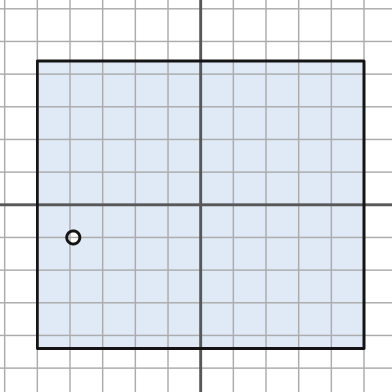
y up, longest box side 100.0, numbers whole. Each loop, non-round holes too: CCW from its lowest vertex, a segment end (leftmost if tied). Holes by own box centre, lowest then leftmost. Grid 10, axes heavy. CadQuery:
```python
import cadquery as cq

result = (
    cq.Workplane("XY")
    .moveTo(-50.0, -44.0)
    .lineTo(50.0, -44.0)
    .lineTo(50.0, 44.0)
    .lineTo(-50.0, 44.0)
    .close()
    .moveTo(-39.0, -10.0)
    .circle(2.0)
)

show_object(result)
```